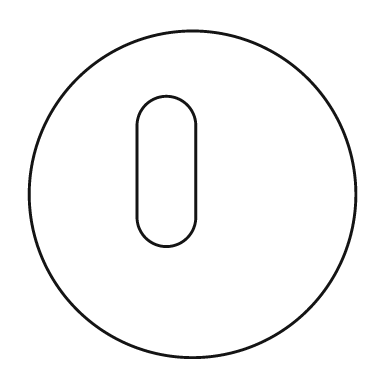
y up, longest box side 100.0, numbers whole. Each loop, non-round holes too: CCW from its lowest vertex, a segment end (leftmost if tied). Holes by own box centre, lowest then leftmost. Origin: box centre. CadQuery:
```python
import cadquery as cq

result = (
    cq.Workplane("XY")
    .moveTo(0.0, 0.0)
    .circle(50.0)
    .moveTo(-17.0, -7.0)
    .threePointArc((-8.0, -16.0), (1.0, -7.0))
    .lineTo(1.0, 21.0)
    .threePointArc((-8.0, 30.0), (-17.0, 21.0))
    .close()
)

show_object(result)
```